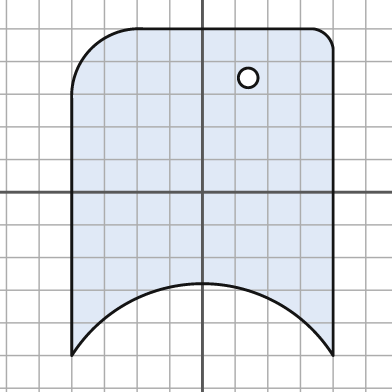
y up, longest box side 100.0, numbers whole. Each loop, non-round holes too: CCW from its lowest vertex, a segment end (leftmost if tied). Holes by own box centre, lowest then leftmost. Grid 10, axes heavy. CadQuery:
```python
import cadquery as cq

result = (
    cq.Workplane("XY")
    .moveTo(-40.0, -50.0)
    .threePointArc((0.0, -28.0), (40.0, -50.0))
    .lineTo(40.0, 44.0)
    .threePointArc((38.0, 48.0), (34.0, 50.0))
    .lineTo(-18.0, 50.0)
    .threePointArc((-34.0, 44.0), (-40.0, 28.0))
    .close()
    .moveTo(14.0, 35.0)
    .circle(3.0)
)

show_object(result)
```